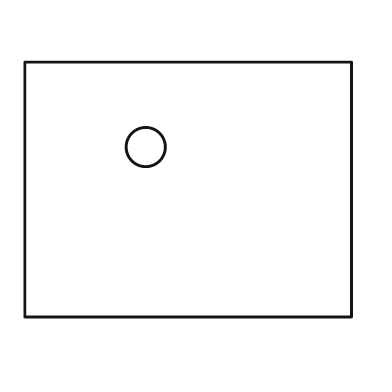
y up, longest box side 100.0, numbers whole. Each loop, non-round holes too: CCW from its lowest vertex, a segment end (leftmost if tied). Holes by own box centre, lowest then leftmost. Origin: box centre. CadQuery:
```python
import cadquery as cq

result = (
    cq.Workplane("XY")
    .moveTo(-50.0, -39.0)
    .lineTo(50.0, -39.0)
    .lineTo(50.0, 39.0)
    .lineTo(-50.0, 39.0)
    .close()
    .moveTo(-13.0, 13.0)
    .circle(6.0)
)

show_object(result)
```